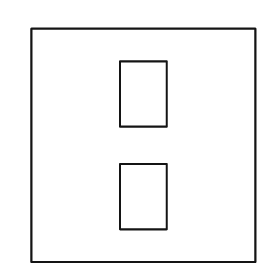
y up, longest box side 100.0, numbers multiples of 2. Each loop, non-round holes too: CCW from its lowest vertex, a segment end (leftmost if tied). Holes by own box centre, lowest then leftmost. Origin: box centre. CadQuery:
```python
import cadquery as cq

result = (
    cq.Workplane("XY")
    .moveTo(-48.0, -50.0)
    .lineTo(48.0, -50.0)
    .lineTo(48.0, 50.0)
    .lineTo(-48.0, 50.0)
    .close()
    .moveTo(-10.0, -36.0)
    .lineTo(10.0, -36.0)
    .lineTo(10.0, -8.0)
    .lineTo(-10.0, -8.0)
    .close()
    .moveTo(-10.0, 8.0)
    .lineTo(10.0, 8.0)
    .lineTo(10.0, 36.0)
    .lineTo(-10.0, 36.0)
    .close()
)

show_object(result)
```